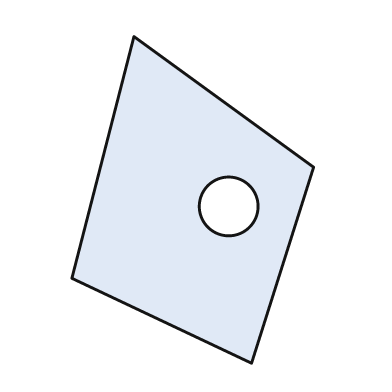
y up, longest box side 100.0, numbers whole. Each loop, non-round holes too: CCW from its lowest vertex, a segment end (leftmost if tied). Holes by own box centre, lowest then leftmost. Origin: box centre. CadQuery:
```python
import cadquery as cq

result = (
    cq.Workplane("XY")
    .moveTo(18.0, -50.0)
    .lineTo(37.0, 10.0)
    .lineTo(-18.0, 50.0)
    .lineTo(-37.0, -24.0)
    .close()
    .moveTo(11.0, -2.0)
    .circle(9.0)
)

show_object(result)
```